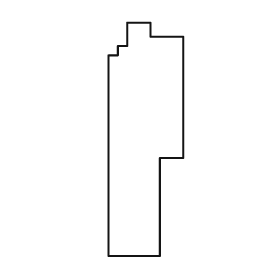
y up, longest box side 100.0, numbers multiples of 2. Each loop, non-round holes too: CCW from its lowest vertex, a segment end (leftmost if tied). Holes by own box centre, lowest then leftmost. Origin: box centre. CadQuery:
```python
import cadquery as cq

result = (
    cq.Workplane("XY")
    .moveTo(-16.0, -50.0)
    .lineTo(6.0, -50.0)
    .lineTo(6.0, -8.0)
    .lineTo(16.0, -8.0)
    .lineTo(16.0, 44.0)
    .lineTo(2.0, 44.0)
    .lineTo(2.0, 50.0)
    .lineTo(-8.0, 50.0)
    .lineTo(-8.0, 40.0)
    .lineTo(-12.0, 40.0)
    .lineTo(-12.0, 36.0)
    .lineTo(-16.0, 36.0)
    .close()
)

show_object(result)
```